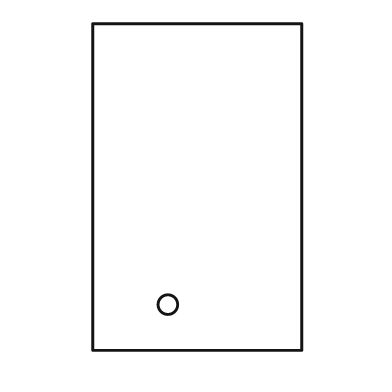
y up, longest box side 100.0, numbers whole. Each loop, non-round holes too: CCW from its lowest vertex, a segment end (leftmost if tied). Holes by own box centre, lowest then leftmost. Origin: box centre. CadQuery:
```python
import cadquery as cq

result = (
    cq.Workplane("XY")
    .moveTo(-32.0, -50.0)
    .lineTo(32.0, -50.0)
    .lineTo(32.0, 50.0)
    .lineTo(-32.0, 50.0)
    .close()
    .moveTo(-9.0, -36.0)
    .circle(3.0)
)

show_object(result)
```